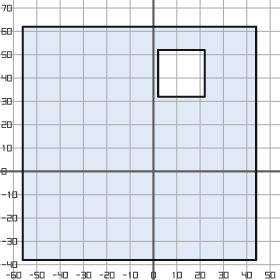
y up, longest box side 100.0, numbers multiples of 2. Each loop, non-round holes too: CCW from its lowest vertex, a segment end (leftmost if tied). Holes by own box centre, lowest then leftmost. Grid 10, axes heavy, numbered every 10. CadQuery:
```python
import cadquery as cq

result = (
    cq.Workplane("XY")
    .moveTo(-56.0, -38.0)
    .lineTo(44.0, -38.0)
    .lineTo(44.0, 62.0)
    .lineTo(-56.0, 62.0)
    .close()
    .moveTo(2.0, 32.0)
    .lineTo(22.0, 32.0)
    .lineTo(22.0, 52.0)
    .lineTo(2.0, 52.0)
    .close()
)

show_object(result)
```